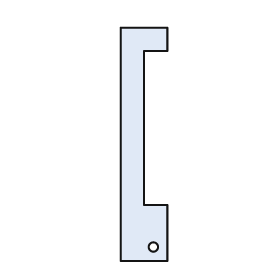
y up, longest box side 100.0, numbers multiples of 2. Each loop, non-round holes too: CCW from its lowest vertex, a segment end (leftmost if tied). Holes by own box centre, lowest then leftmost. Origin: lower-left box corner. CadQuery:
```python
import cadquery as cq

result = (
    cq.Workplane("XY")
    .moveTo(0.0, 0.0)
    .lineTo(20.0, 0.0)
    .lineTo(20.0, 24.0)
    .lineTo(10.0, 24.0)
    .lineTo(10.0, 90.0)
    .lineTo(20.0, 90.0)
    .lineTo(20.0, 100.0)
    .lineTo(0.0, 100.0)
    .close()
    .moveTo(14.0, 6.0)
    .circle(2.0)
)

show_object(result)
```